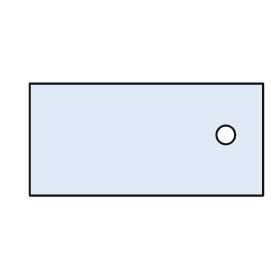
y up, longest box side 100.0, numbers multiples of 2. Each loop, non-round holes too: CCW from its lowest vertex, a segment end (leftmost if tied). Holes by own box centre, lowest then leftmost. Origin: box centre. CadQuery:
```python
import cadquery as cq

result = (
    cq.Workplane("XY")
    .moveTo(-50.0, -24.0)
    .lineTo(50.0, -24.0)
    .lineTo(50.0, 24.0)
    .lineTo(-50.0, 24.0)
    .close()
    .moveTo(34.0, 2.0)
    .circle(4.0)
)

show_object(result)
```